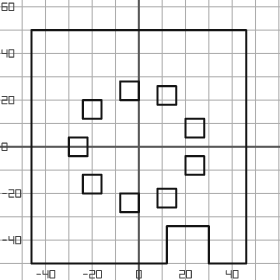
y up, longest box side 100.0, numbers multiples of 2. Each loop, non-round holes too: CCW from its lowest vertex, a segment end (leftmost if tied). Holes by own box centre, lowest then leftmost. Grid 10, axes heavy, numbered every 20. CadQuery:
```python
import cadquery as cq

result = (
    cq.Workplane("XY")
    .moveTo(-46.0, -50.0)
    .lineTo(12.0, -50.0)
    .lineTo(12.0, -34.0)
    .lineTo(30.0, -34.0)
    .lineTo(30.0, -50.0)
    .lineTo(46.0, -50.0)
    .lineTo(46.0, 50.0)
    .lineTo(-46.0, 50.0)
    .close()
    .moveTo(-8.0, -28.0)
    .lineTo(0.0, -28.0)
    .lineTo(0.0, -20.0)
    .lineTo(-8.0, -20.0)
    .close()
    .moveTo(8.0, -26.0)
    .lineTo(16.0, -26.0)
    .lineTo(16.0, -18.0)
    .lineTo(8.0, -18.0)
    .close()
    .moveTo(-24.0, -20.0)
    .lineTo(-16.0, -20.0)
    .lineTo(-16.0, -12.0)
    .lineTo(-24.0, -12.0)
    .close()
    .moveTo(20.0, -12.0)
    .lineTo(28.0, -12.0)
    .lineTo(28.0, -4.0)
    .lineTo(20.0, -4.0)
    .close()
    .moveTo(-30.0, -4.0)
    .lineTo(-22.0, -4.0)
    .lineTo(-22.0, 4.0)
    .lineTo(-30.0, 4.0)
    .close()
    .moveTo(20.0, 4.0)
    .lineTo(28.0, 4.0)
    .lineTo(28.0, 12.0)
    .lineTo(20.0, 12.0)
    .close()
    .moveTo(-24.0, 12.0)
    .lineTo(-16.0, 12.0)
    .lineTo(-16.0, 20.0)
    .lineTo(-24.0, 20.0)
    .close()
    .moveTo(8.0, 18.0)
    .lineTo(16.0, 18.0)
    .lineTo(16.0, 26.0)
    .lineTo(8.0, 26.0)
    .close()
    .moveTo(-8.0, 20.0)
    .lineTo(0.0, 20.0)
    .lineTo(0.0, 28.0)
    .lineTo(-8.0, 28.0)
    .close()
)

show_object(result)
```